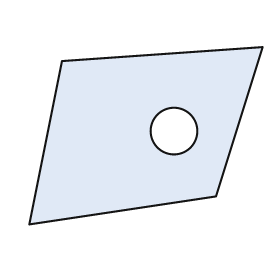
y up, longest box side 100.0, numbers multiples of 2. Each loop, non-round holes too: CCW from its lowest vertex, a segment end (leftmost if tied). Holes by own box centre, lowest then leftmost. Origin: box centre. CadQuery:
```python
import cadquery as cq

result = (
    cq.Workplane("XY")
    .moveTo(-50.0, -38.0)
    .lineTo(30.0, -26.0)
    .lineTo(50.0, 38.0)
    .lineTo(-36.0, 32.0)
    .close()
    .moveTo(12.0, 2.0)
    .circle(10.0)
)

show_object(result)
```